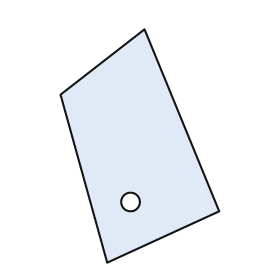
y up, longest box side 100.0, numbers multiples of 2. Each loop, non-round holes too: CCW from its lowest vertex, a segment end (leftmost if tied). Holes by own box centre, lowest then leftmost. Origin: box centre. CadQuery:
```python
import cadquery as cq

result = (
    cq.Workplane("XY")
    .moveTo(-14.0, -50.0)
    .lineTo(34.0, -28.0)
    .lineTo(2.0, 50.0)
    .lineTo(-34.0, 22.0)
    .close()
    .moveTo(-4.0, -24.0)
    .circle(4.0)
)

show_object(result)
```